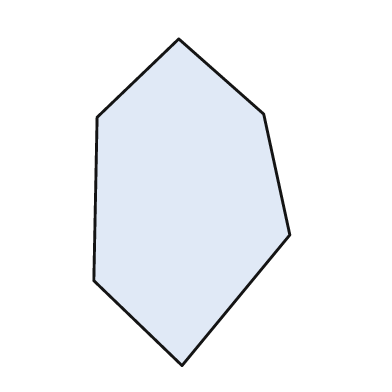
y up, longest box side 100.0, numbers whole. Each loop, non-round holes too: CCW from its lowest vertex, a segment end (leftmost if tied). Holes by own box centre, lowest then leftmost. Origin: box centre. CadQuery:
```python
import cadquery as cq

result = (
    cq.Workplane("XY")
    .moveTo(-3.0, -50.0)
    .lineTo(30.0, -10.0)
    .lineTo(22.0, 27.0)
    .lineTo(-4.0, 50.0)
    .lineTo(-29.0, 26.0)
    .lineTo(-30.0, -24.0)
    .close()
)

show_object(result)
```